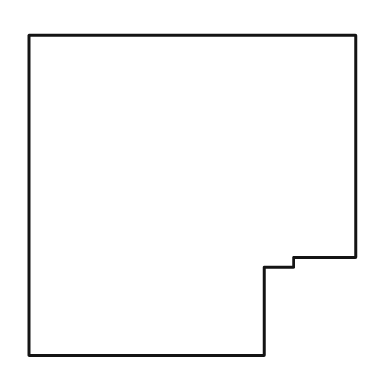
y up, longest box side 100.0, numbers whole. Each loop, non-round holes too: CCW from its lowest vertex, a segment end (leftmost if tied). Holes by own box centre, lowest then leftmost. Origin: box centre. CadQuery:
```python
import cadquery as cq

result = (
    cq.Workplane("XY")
    .moveTo(-50.0, -49.0)
    .lineTo(22.0, -49.0)
    .lineTo(22.0, -22.0)
    .lineTo(31.0, -22.0)
    .lineTo(31.0, -19.0)
    .lineTo(50.0, -19.0)
    .lineTo(50.0, 49.0)
    .lineTo(-50.0, 49.0)
    .close()
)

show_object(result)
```